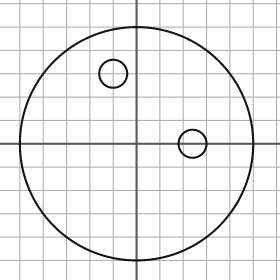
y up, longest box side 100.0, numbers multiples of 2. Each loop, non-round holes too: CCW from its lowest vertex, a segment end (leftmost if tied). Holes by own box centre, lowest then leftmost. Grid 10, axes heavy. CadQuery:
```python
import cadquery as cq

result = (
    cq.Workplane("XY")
    .moveTo(0.0, 0.0)
    .circle(50.0)
    .moveTo(24.0, 0.0)
    .circle(6.0)
    .moveTo(-10.0, 30.0)
    .circle(6.0)
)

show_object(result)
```